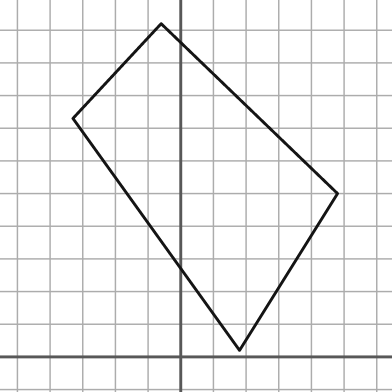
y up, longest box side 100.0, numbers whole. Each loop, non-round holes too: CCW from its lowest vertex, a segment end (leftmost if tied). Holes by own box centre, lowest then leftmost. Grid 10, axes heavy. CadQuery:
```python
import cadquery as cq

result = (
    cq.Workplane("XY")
    .moveTo(18.0, 2.0)
    .lineTo(48.0, 50.0)
    .lineTo(-6.0, 102.0)
    .lineTo(-33.0, 73.0)
    .close()
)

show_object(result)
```